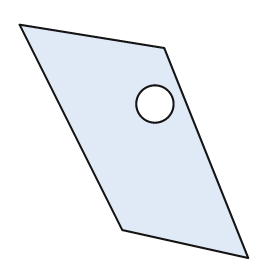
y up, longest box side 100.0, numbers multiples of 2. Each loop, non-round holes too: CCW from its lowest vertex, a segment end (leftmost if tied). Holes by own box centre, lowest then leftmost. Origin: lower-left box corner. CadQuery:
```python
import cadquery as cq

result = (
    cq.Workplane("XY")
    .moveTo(98.0, 0.0)
    .lineTo(62.0, 90.0)
    .lineTo(0.0, 100.0)
    .lineTo(44.0, 12.0)
    .close()
    .moveTo(58.0, 66.0)
    .circle(8.0)
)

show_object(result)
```